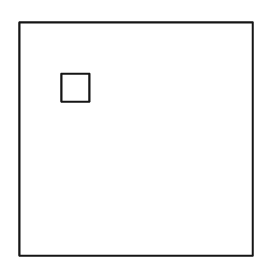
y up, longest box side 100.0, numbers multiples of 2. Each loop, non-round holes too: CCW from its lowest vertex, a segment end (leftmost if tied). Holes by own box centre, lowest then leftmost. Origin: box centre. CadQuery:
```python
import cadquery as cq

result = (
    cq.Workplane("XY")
    .moveTo(-50.0, -50.0)
    .lineTo(50.0, -50.0)
    .lineTo(50.0, 50.0)
    .lineTo(-50.0, 50.0)
    .close()
    .moveTo(-32.0, 16.0)
    .lineTo(-20.0, 16.0)
    .lineTo(-20.0, 28.0)
    .lineTo(-32.0, 28.0)
    .close()
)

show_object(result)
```